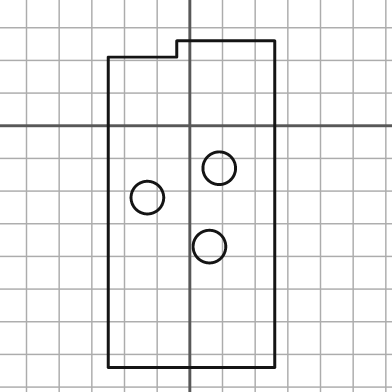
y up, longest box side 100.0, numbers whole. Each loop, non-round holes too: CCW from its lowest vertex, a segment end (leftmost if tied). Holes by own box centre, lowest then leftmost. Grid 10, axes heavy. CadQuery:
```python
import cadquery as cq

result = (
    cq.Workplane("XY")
    .moveTo(-25.0, -74.0)
    .lineTo(26.0, -74.0)
    .lineTo(26.0, 26.0)
    .lineTo(-4.0, 26.0)
    .lineTo(-4.0, 21.0)
    .lineTo(-25.0, 21.0)
    .close()
    .moveTo(6.0, -37.0)
    .circle(5.0)
    .moveTo(-13.0, -22.0)
    .circle(5.0)
    .moveTo(9.0, -13.0)
    .circle(5.0)
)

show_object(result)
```